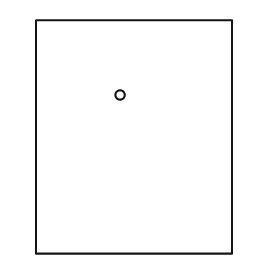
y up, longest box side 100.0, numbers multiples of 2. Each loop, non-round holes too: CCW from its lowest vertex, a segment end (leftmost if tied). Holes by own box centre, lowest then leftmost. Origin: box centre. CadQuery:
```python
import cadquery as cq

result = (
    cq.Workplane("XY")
    .moveTo(-42.0, -50.0)
    .lineTo(42.0, -50.0)
    .lineTo(42.0, 50.0)
    .lineTo(-42.0, 50.0)
    .close()
    .moveTo(-6.0, 18.0)
    .circle(2.0)
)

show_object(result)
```